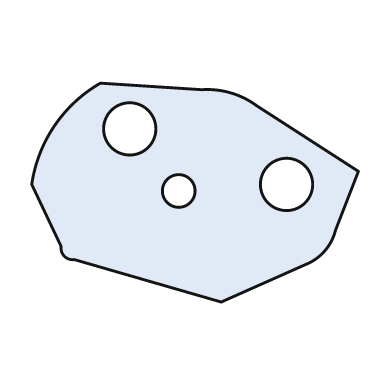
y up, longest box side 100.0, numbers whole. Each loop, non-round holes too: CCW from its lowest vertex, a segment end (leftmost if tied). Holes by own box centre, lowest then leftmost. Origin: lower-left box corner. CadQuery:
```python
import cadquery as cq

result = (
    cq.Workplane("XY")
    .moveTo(58.0, 0.0)
    .lineTo(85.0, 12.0)
    .threePointArc((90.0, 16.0), (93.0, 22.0))
    .lineTo(100.0, 40.0)
    .lineTo(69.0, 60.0)
    .threePointArc((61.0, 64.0), (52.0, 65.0))
    .lineTo(21.0, 67.0)
    .threePointArc((7.0, 54.0), (0.0, 36.0))
    .lineTo(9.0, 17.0)
    .threePointArc((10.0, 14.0), (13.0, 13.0))
    .close()
    .moveTo(45.0, 34.0)
    .circle(5.0)
    .moveTo(78.0, 36.0)
    .circle(8.0)
    .moveTo(30.0, 53.0)
    .circle(8.0)
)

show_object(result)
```